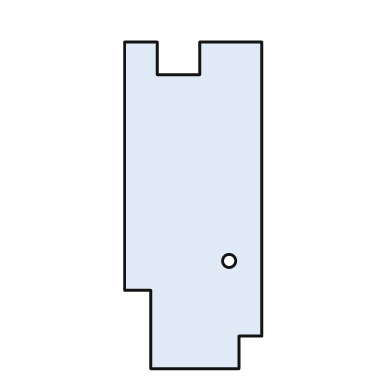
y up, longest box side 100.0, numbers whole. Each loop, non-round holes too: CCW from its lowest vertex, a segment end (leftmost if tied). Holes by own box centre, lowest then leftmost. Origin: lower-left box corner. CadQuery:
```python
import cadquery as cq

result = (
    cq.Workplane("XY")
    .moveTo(8.0, 0.0)
    .lineTo(35.0, 0.0)
    .lineTo(35.0, 10.0)
    .lineTo(42.0, 10.0)
    .lineTo(42.0, 100.0)
    .lineTo(23.0, 100.0)
    .lineTo(23.0, 90.0)
    .lineTo(10.0, 90.0)
    .lineTo(10.0, 100.0)
    .lineTo(0.0, 100.0)
    .lineTo(0.0, 24.0)
    .lineTo(8.0, 24.0)
    .close()
    .moveTo(32.0, 33.0)
    .circle(2.0)
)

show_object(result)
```